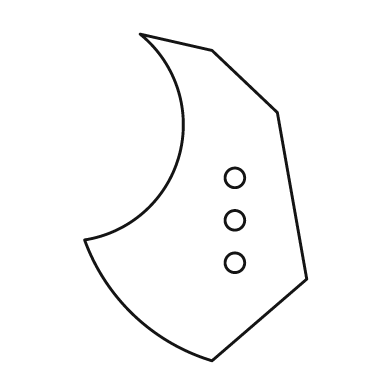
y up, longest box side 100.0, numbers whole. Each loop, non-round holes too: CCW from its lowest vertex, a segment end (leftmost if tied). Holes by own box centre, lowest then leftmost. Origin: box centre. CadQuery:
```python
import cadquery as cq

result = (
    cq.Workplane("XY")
    .moveTo(5.0, -50.0)
    .lineTo(34.0, -25.0)
    .lineTo(25.0, 26.0)
    .lineTo(5.0, 45.0)
    .lineTo(-17.0, 50.0)
    .threePointArc((-5.0, 13.0), (-34.0, -13.0))
    .threePointArc((-19.0, -36.0), (5.0, -50.0))
    .close()
    .moveTo(12.0, -20.0)
    .circle(3.0)
    .moveTo(12.0, -7.0)
    .circle(3.0)
    .moveTo(12.0, 6.0)
    .circle(3.0)
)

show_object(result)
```